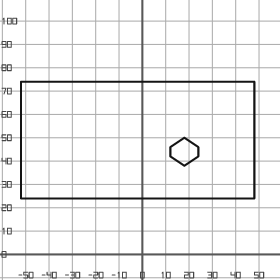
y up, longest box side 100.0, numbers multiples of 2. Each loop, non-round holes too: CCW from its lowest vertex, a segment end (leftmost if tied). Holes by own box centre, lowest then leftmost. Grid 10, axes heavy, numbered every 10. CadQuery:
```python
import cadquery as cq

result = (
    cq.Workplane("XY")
    .moveTo(-52.0, 24.0)
    .lineTo(48.0, 24.0)
    .lineTo(48.0, 74.0)
    .lineTo(-52.0, 74.0)
    .close()
    .moveTo(18.0, 38.0)
    .lineTo(24.0, 42.0)
    .lineTo(24.0, 46.0)
    .lineTo(18.0, 50.0)
    .lineTo(12.0, 46.0)
    .lineTo(12.0, 42.0)
    .close()
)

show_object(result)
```